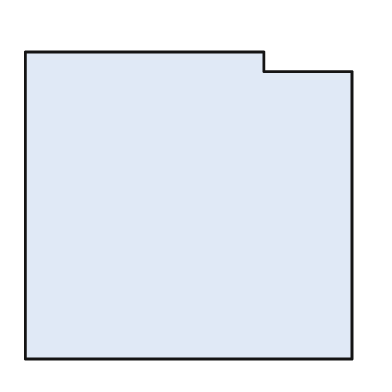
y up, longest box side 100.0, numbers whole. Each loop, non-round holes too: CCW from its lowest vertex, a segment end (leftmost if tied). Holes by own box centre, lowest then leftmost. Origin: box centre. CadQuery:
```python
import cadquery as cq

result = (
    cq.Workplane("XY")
    .moveTo(-50.0, -47.0)
    .lineTo(50.0, -47.0)
    .lineTo(50.0, 41.0)
    .lineTo(23.0, 41.0)
    .lineTo(23.0, 47.0)
    .lineTo(-50.0, 47.0)
    .close()
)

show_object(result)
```